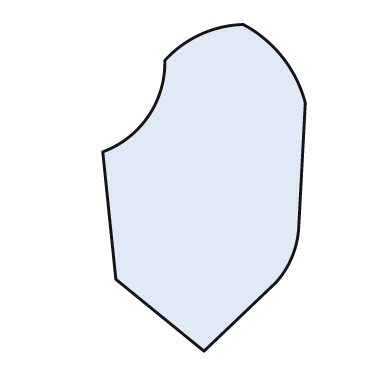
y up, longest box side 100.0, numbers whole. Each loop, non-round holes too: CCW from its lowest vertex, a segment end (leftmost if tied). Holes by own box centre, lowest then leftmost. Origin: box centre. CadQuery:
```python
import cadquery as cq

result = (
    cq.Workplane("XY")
    .moveTo(0.0, -50.0)
    .lineTo(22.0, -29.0)
    .threePointArc((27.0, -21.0), (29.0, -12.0))
    .lineTo(31.0, 26.0)
    .threePointArc((24.0, 40.0), (12.0, 50.0))
    .threePointArc((-1.0, 47.0), (-12.0, 39.0))
    .threePointArc((-17.0, 22.0), (-31.0, 11.0))
    .lineTo(-27.0, -28.0)
    .close()
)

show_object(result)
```